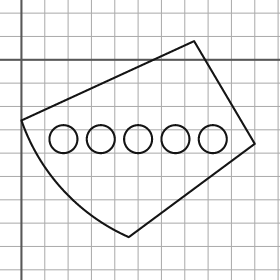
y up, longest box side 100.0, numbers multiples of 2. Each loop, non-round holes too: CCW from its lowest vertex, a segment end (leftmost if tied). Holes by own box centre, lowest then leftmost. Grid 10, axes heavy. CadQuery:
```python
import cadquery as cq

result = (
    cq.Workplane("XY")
    .moveTo(46.0, -76.0)
    .lineTo(100.0, -36.0)
    .lineTo(74.0, 8.0)
    .lineTo(0.0, -26.0)
    .threePointArc((18.0, -56.0), (46.0, -76.0))
    .close()
    .moveTo(18.0, -34.0)
    .circle(6.0)
    .moveTo(34.0, -34.0)
    .circle(6.0)
    .moveTo(50.0, -34.0)
    .circle(6.0)
    .moveTo(66.0, -34.0)
    .circle(6.0)
    .moveTo(82.0, -34.0)
    .circle(6.0)
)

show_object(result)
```